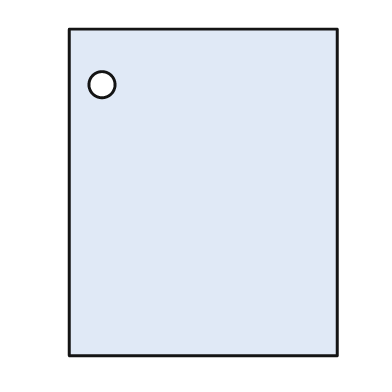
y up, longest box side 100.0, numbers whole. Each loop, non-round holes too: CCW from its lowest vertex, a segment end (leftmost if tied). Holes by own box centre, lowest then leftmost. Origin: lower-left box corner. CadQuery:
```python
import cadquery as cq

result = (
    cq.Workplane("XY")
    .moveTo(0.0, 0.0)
    .lineTo(82.0, 0.0)
    .lineTo(82.0, 100.0)
    .lineTo(0.0, 100.0)
    .close()
    .moveTo(10.0, 83.0)
    .circle(4.0)
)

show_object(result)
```